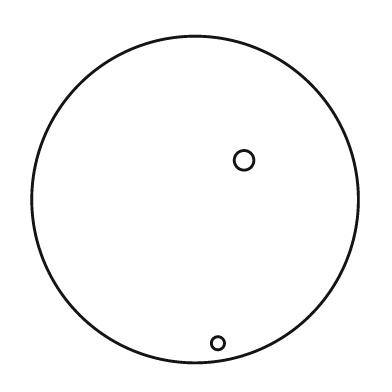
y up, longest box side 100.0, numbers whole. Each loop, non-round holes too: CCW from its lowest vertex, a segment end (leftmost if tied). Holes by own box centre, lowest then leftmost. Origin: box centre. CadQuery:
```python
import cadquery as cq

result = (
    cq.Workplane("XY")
    .moveTo(0.0, 0.0)
    .circle(50.0)
    .moveTo(7.0, -44.0)
    .circle(2.0)
    .moveTo(15.0, 12.0)
    .circle(3.0)
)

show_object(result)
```